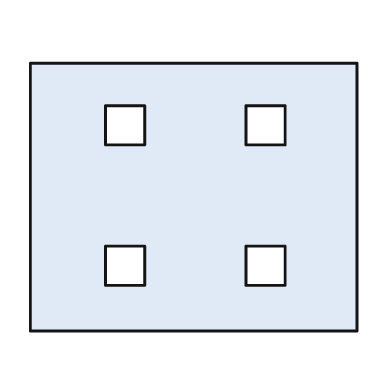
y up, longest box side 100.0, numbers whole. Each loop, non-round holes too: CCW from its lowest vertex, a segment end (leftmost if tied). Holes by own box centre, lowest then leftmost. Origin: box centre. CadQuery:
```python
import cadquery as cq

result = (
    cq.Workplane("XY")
    .moveTo(-50.0, -41.0)
    .lineTo(50.0, -41.0)
    .lineTo(50.0, 41.0)
    .lineTo(-50.0, 41.0)
    .close()
    .moveTo(-27.0, -27.0)
    .lineTo(-15.0, -27.0)
    .lineTo(-15.0, -15.0)
    .lineTo(-27.0, -15.0)
    .close()
    .moveTo(16.0, -27.0)
    .lineTo(28.0, -27.0)
    .lineTo(28.0, -15.0)
    .lineTo(16.0, -15.0)
    .close()
    .moveTo(-27.0, 16.0)
    .lineTo(-15.0, 16.0)
    .lineTo(-15.0, 28.0)
    .lineTo(-27.0, 28.0)
    .close()
    .moveTo(16.0, 16.0)
    .lineTo(28.0, 16.0)
    .lineTo(28.0, 28.0)
    .lineTo(16.0, 28.0)
    .close()
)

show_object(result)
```